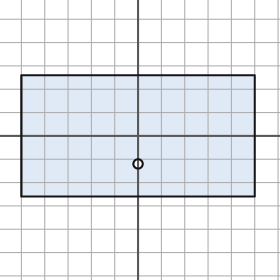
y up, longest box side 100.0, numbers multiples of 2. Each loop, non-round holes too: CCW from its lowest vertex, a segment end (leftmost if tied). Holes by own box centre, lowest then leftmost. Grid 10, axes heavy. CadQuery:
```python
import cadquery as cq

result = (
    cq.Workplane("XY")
    .moveTo(-50.0, -26.0)
    .lineTo(50.0, -26.0)
    .lineTo(50.0, 26.0)
    .lineTo(-50.0, 26.0)
    .close()
    .moveTo(0.0, -12.0)
    .circle(2.0)
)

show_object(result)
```